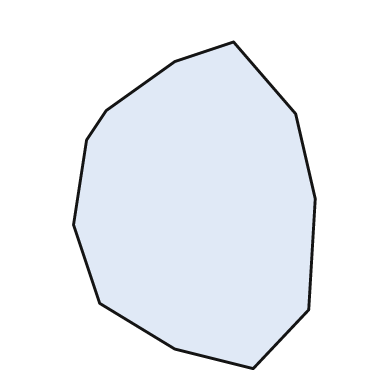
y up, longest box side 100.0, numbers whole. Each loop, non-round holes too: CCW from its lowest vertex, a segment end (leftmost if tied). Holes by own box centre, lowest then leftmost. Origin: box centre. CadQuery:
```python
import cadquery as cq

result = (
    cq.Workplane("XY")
    .moveTo(18.0, -50.0)
    .lineTo(35.0, -32.0)
    .lineTo(37.0, 2.0)
    .lineTo(31.0, 28.0)
    .lineTo(12.0, 50.0)
    .lineTo(-6.0, 44.0)
    .lineTo(-27.0, 29.0)
    .lineTo(-33.0, 20.0)
    .lineTo(-37.0, -6.0)
    .lineTo(-29.0, -30.0)
    .lineTo(-6.0, -44.0)
    .close()
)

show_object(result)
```